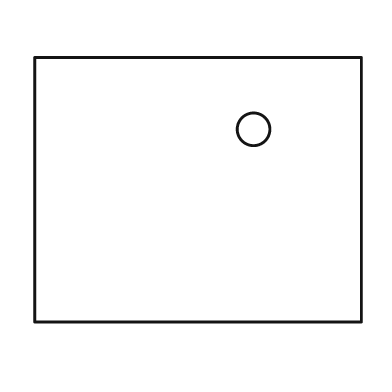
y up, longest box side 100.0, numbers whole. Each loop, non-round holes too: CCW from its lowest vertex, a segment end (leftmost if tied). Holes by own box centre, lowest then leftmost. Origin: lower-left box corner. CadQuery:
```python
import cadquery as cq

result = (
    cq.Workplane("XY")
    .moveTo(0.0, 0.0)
    .lineTo(100.0, 0.0)
    .lineTo(100.0, 81.0)
    .lineTo(0.0, 81.0)
    .close()
    .moveTo(67.0, 59.0)
    .circle(5.0)
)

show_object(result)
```